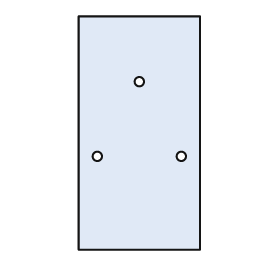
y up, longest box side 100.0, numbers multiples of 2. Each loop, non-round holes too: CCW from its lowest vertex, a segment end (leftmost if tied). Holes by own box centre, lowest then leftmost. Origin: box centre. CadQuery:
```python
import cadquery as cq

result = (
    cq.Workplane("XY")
    .moveTo(-26.0, -50.0)
    .lineTo(26.0, -50.0)
    .lineTo(26.0, 50.0)
    .lineTo(-26.0, 50.0)
    .close()
    .moveTo(-18.0, -10.0)
    .circle(2.0)
    .moveTo(18.0, -10.0)
    .circle(2.0)
    .moveTo(0.0, 22.0)
    .circle(2.0)
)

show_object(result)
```